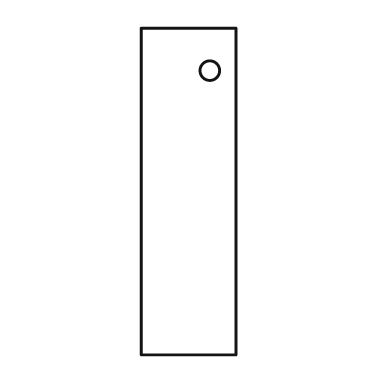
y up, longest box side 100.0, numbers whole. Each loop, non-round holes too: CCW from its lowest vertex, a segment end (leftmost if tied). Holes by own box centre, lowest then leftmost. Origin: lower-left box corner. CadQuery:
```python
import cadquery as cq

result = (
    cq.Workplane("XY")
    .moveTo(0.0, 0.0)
    .lineTo(29.0, 0.0)
    .lineTo(29.0, 100.0)
    .lineTo(0.0, 100.0)
    .close()
    .moveTo(21.0, 87.0)
    .circle(3.0)
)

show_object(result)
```